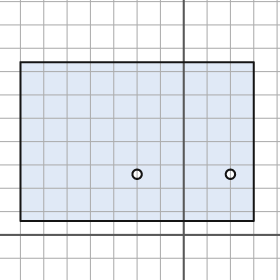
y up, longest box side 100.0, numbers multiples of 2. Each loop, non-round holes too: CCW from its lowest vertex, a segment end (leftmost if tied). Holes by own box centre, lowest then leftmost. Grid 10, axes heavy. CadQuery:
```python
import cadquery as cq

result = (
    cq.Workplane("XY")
    .moveTo(-70.0, 6.0)
    .lineTo(30.0, 6.0)
    .lineTo(30.0, 74.0)
    .lineTo(-70.0, 74.0)
    .close()
    .moveTo(-20.0, 26.0)
    .circle(2.0)
    .moveTo(20.0, 26.0)
    .circle(2.0)
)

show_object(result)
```